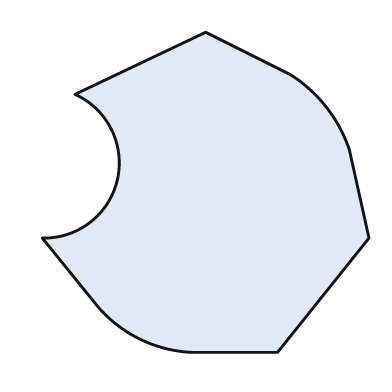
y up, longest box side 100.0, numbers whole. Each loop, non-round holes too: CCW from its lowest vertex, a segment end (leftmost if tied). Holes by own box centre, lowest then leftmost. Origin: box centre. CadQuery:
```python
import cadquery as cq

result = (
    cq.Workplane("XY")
    .moveTo(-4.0, -49.0)
    .lineTo(22.0, -49.0)
    .lineTo(50.0, -14.0)
    .lineTo(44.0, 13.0)
    .threePointArc((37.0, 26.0), (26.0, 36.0))
    .lineTo(0.0, 49.0)
    .lineTo(-40.0, 30.0)
    .threePointArc((-27.0, 4.0), (-50.0, -14.0))
    .lineTo(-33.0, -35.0)
    .threePointArc((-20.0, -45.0), (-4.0, -49.0))
    .close()
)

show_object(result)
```